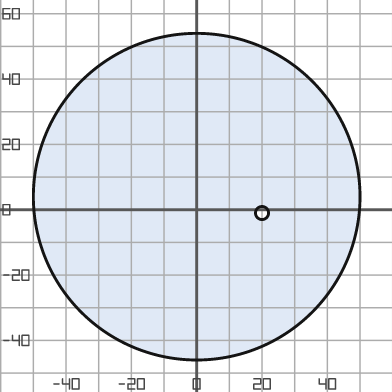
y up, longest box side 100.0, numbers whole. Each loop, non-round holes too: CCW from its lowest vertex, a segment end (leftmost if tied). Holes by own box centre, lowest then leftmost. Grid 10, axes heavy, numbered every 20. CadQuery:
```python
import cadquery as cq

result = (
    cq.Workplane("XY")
    .moveTo(0.0, 4.0)
    .circle(50.0)
    .moveTo(20.0, -1.0)
    .circle(2.0)
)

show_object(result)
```